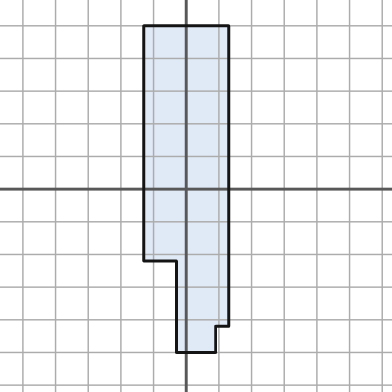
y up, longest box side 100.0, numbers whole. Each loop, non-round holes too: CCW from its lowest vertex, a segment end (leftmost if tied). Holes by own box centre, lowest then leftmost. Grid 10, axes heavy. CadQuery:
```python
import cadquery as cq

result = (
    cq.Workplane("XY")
    .moveTo(-3.0, -50.0)
    .lineTo(9.0, -50.0)
    .lineTo(9.0, -42.0)
    .lineTo(13.0, -42.0)
    .lineTo(13.0, 50.0)
    .lineTo(-13.0, 50.0)
    .lineTo(-13.0, -22.0)
    .lineTo(-3.0, -22.0)
    .close()
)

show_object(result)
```